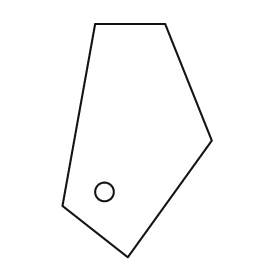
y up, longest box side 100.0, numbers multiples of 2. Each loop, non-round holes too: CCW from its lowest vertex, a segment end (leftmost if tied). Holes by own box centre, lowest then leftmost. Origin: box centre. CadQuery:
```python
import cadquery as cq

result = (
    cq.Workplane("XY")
    .moveTo(-4.0, -50.0)
    .lineTo(32.0, 0.0)
    .lineTo(12.0, 50.0)
    .lineTo(-18.0, 50.0)
    .lineTo(-32.0, -28.0)
    .close()
    .moveTo(-14.0, -22.0)
    .circle(4.0)
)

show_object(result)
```